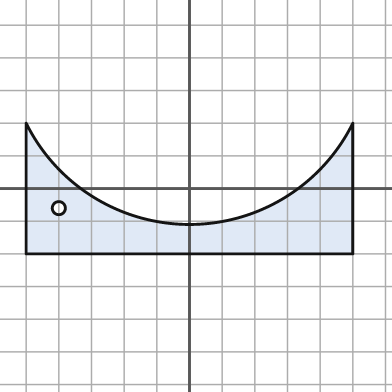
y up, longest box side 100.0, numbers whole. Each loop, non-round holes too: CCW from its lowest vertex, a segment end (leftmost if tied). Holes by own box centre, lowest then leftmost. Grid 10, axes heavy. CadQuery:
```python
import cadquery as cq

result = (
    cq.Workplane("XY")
    .moveTo(-50.0, -20.0)
    .lineTo(50.0, -20.0)
    .lineTo(50.0, 20.0)
    .threePointArc((0.0, -11.0), (-50.0, 20.0))
    .close()
    .moveTo(-40.0, -6.0)
    .circle(2.0)
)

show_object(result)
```